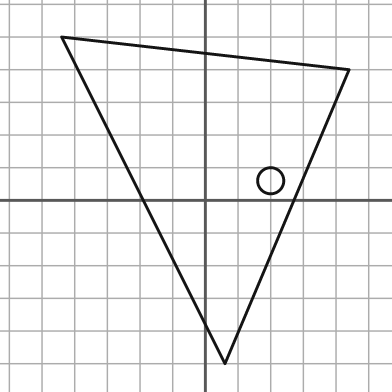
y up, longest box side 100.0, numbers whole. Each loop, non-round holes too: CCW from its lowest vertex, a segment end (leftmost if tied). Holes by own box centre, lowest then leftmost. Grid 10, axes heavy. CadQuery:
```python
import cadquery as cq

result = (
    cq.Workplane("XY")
    .moveTo(6.0, -50.0)
    .lineTo(44.0, 40.0)
    .lineTo(-44.0, 50.0)
    .close()
    .moveTo(20.0, 6.0)
    .circle(4.0)
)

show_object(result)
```